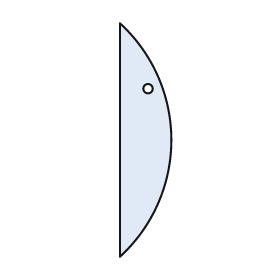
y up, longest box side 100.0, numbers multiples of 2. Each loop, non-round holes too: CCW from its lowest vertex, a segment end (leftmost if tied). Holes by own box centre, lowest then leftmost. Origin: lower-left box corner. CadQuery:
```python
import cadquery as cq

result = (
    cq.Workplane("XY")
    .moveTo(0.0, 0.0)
    .threePointArc((22.0, 50.0), (0.0, 100.0))
    .close()
    .moveTo(12.0, 72.0)
    .circle(2.0)
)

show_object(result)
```